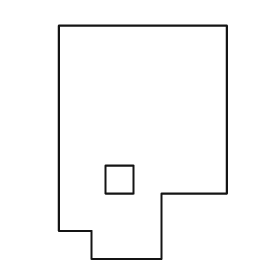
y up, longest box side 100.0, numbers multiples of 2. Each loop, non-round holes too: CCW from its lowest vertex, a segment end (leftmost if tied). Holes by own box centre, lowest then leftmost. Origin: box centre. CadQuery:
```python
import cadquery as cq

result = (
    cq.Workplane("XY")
    .moveTo(-22.0, -50.0)
    .lineTo(8.0, -50.0)
    .lineTo(8.0, -22.0)
    .lineTo(36.0, -22.0)
    .lineTo(36.0, 50.0)
    .lineTo(-36.0, 50.0)
    .lineTo(-36.0, -38.0)
    .lineTo(-22.0, -38.0)
    .close()
    .moveTo(-16.0, -22.0)
    .lineTo(-4.0, -22.0)
    .lineTo(-4.0, -10.0)
    .lineTo(-16.0, -10.0)
    .close()
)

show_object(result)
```